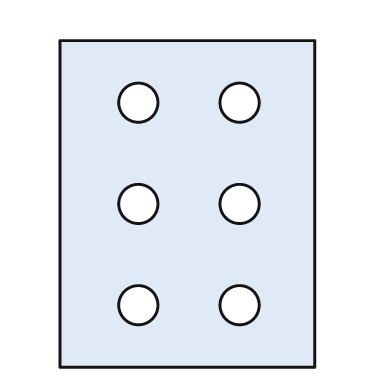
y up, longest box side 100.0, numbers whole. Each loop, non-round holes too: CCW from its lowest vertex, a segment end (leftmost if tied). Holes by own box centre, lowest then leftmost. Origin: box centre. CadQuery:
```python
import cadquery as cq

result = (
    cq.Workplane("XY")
    .moveTo(-39.0, -50.0)
    .lineTo(39.0, -50.0)
    .lineTo(39.0, 50.0)
    .lineTo(-39.0, 50.0)
    .close()
    .moveTo(-15.0, -31.0)
    .circle(6.0)
    .moveTo(16.0, -31.0)
    .circle(6.0)
    .moveTo(-15.0, 0.0)
    .circle(6.0)
    .moveTo(16.0, 0.0)
    .circle(6.0)
    .moveTo(-15.0, 31.0)
    .circle(6.0)
    .moveTo(16.0, 31.0)
    .circle(6.0)
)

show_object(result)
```